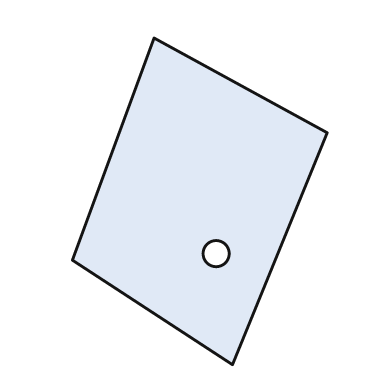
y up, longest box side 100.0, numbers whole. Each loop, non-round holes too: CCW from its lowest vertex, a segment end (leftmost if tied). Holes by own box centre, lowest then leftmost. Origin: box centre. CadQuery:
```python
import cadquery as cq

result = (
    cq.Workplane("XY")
    .moveTo(10.0, -50.0)
    .lineTo(39.0, 21.0)
    .lineTo(-14.0, 50.0)
    .lineTo(-39.0, -18.0)
    .close()
    .moveTo(5.0, -16.0)
    .circle(4.0)
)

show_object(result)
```